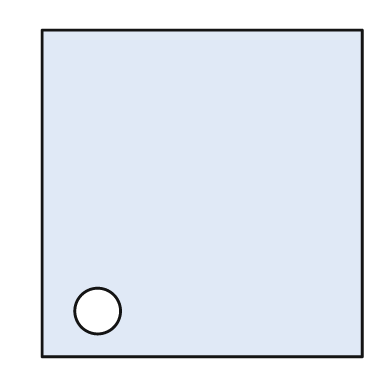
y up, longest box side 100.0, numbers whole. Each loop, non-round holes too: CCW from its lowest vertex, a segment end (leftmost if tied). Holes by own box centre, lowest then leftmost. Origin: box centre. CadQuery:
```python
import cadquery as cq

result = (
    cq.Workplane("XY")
    .moveTo(-49.0, -50.0)
    .lineTo(49.0, -50.0)
    .lineTo(49.0, 50.0)
    .lineTo(-49.0, 50.0)
    .close()
    .moveTo(-32.0, -36.0)
    .circle(7.0)
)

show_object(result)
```